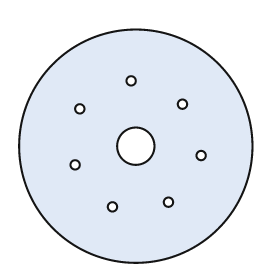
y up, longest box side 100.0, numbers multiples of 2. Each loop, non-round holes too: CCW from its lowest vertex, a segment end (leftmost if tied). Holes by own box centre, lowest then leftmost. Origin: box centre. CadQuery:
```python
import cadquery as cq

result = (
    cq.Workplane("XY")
    .moveTo(0.0, 0.0)
    .circle(50.0)
    .moveTo(-10.0, -26.0)
    .circle(2.0)
    .moveTo(14.0, -24.0)
    .circle(2.0)
    .moveTo(-26.0, -8.0)
    .circle(2.0)
    .moveTo(28.0, -4.0)
    .circle(2.0)
    .moveTo(0.0, 0.0)
    .circle(8.0)
    .moveTo(-24.0, 16.0)
    .circle(2.0)
    .moveTo(20.0, 18.0)
    .circle(2.0)
    .moveTo(-2.0, 28.0)
    .circle(2.0)
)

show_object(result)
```